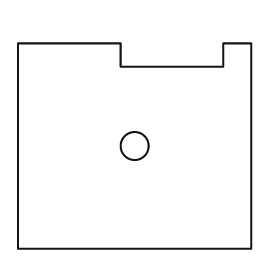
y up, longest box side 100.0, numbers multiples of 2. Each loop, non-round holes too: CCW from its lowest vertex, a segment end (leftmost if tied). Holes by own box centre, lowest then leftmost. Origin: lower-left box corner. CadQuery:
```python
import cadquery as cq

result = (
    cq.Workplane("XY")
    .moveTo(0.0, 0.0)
    .lineTo(100.0, 0.0)
    .lineTo(100.0, 88.0)
    .lineTo(88.0, 88.0)
    .lineTo(88.0, 78.0)
    .lineTo(44.0, 78.0)
    .lineTo(44.0, 88.0)
    .lineTo(0.0, 88.0)
    .close()
    .moveTo(50.0, 44.0)
    .circle(6.0)
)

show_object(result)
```